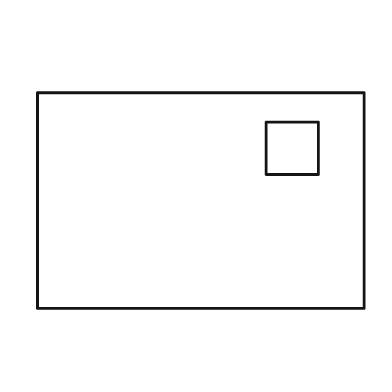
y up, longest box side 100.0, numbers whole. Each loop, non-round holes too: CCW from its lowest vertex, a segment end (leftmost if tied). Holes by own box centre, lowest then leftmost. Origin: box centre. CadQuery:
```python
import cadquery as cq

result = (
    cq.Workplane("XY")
    .moveTo(-50.0, -33.0)
    .lineTo(50.0, -33.0)
    .lineTo(50.0, 33.0)
    .lineTo(-50.0, 33.0)
    .close()
    .moveTo(20.0, 8.0)
    .lineTo(36.0, 8.0)
    .lineTo(36.0, 24.0)
    .lineTo(20.0, 24.0)
    .close()
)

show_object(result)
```